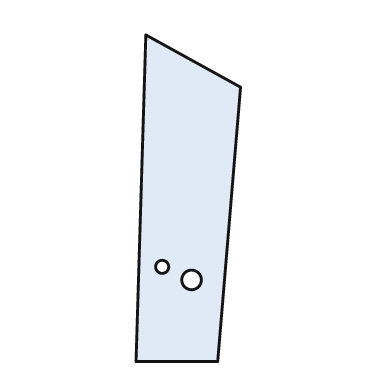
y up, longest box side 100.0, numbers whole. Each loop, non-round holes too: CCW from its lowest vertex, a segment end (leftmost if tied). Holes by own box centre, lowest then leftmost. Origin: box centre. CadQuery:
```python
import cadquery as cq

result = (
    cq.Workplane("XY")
    .moveTo(-16.0, -50.0)
    .lineTo(9.0, -50.0)
    .lineTo(16.0, 34.0)
    .lineTo(-13.0, 50.0)
    .close()
    .moveTo(1.0, -25.0)
    .circle(3.0)
    .moveTo(-8.0, -21.0)
    .circle(2.0)
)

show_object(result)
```